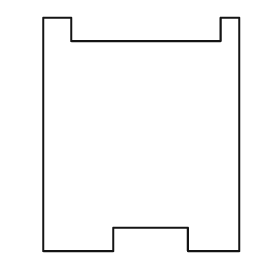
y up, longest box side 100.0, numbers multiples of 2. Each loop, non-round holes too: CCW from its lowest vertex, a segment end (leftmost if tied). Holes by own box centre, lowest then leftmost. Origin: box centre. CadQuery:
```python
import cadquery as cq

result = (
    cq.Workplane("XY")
    .moveTo(-42.0, -50.0)
    .lineTo(-12.0, -50.0)
    .lineTo(-12.0, -40.0)
    .lineTo(20.0, -40.0)
    .lineTo(20.0, -50.0)
    .lineTo(42.0, -50.0)
    .lineTo(42.0, 50.0)
    .lineTo(34.0, 50.0)
    .lineTo(34.0, 40.0)
    .lineTo(-30.0, 40.0)
    .lineTo(-30.0, 50.0)
    .lineTo(-42.0, 50.0)
    .close()
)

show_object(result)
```